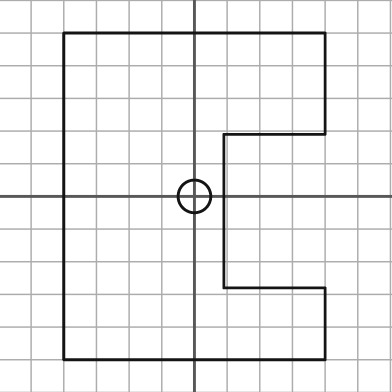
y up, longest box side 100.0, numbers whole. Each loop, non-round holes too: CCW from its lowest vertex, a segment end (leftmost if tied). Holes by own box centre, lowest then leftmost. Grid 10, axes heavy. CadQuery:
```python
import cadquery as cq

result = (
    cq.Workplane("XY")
    .moveTo(-40.0, -50.0)
    .lineTo(40.0, -50.0)
    .lineTo(40.0, -28.0)
    .lineTo(9.0, -28.0)
    .lineTo(9.0, 19.0)
    .lineTo(40.0, 19.0)
    .lineTo(40.0, 50.0)
    .lineTo(-40.0, 50.0)
    .close()
    .moveTo(0.0, 0.0)
    .circle(5.0)
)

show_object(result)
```